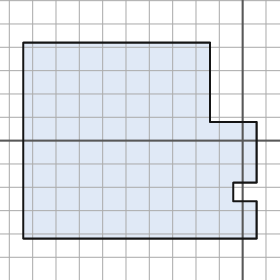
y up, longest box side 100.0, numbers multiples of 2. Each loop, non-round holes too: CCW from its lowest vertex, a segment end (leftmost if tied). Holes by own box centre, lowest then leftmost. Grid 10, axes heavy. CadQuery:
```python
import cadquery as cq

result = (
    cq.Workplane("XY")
    .moveTo(-94.0, -42.0)
    .lineTo(6.0, -42.0)
    .lineTo(6.0, -26.0)
    .lineTo(-4.0, -26.0)
    .lineTo(-4.0, -18.0)
    .lineTo(6.0, -18.0)
    .lineTo(6.0, 8.0)
    .lineTo(-14.0, 8.0)
    .lineTo(-14.0, 42.0)
    .lineTo(-94.0, 42.0)
    .close()
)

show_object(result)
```